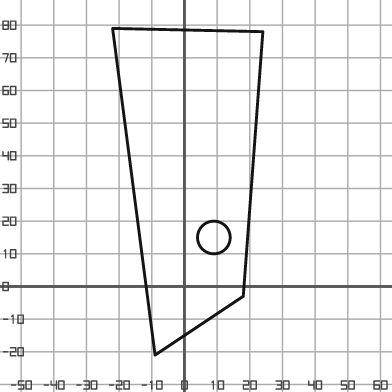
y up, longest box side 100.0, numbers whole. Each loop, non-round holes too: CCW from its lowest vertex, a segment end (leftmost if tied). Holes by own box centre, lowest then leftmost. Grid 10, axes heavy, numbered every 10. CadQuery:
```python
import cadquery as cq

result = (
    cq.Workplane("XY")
    .moveTo(-9.0, -21.0)
    .lineTo(18.0, -3.0)
    .lineTo(24.0, 78.0)
    .lineTo(-22.0, 79.0)
    .close()
    .moveTo(9.0, 15.0)
    .circle(5.0)
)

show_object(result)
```